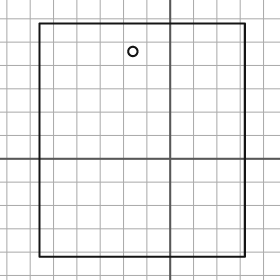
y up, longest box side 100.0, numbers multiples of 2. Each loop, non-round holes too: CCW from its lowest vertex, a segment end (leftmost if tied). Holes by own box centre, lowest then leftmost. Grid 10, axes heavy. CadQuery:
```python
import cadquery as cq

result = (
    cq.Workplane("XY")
    .moveTo(-56.0, -42.0)
    .lineTo(32.0, -42.0)
    .lineTo(32.0, 58.0)
    .lineTo(-56.0, 58.0)
    .close()
    .moveTo(-16.0, 46.0)
    .circle(2.0)
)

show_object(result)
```